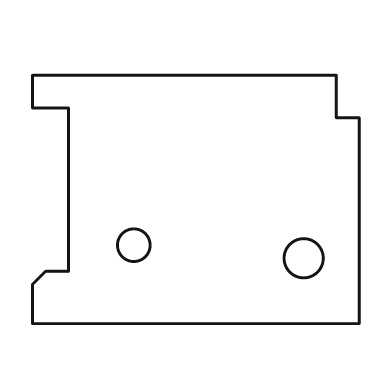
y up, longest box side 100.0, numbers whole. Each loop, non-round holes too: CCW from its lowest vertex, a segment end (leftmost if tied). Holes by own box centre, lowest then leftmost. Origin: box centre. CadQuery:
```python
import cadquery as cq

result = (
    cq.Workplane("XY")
    .moveTo(-50.0, -38.0)
    .lineTo(50.0, -38.0)
    .lineTo(50.0, 25.0)
    .lineTo(43.0, 25.0)
    .lineTo(43.0, 38.0)
    .lineTo(-50.0, 38.0)
    .lineTo(-50.0, 28.0)
    .lineTo(-39.0, 28.0)
    .lineTo(-39.0, -22.0)
    .lineTo(-46.0, -22.0)
    .lineTo(-50.0, -26.0)
    .close()
    .moveTo(33.0, -18.0)
    .circle(6.0)
    .moveTo(-19.0, -14.0)
    .circle(5.0)
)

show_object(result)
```